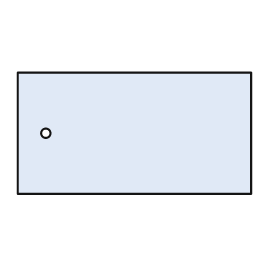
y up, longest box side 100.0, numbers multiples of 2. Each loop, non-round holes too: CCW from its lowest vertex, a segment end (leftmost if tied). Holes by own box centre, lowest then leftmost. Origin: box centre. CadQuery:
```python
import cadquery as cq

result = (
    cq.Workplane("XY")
    .moveTo(-50.0, -26.0)
    .lineTo(50.0, -26.0)
    .lineTo(50.0, 26.0)
    .lineTo(-50.0, 26.0)
    .close()
    .moveTo(-38.0, 0.0)
    .circle(2.0)
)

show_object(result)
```